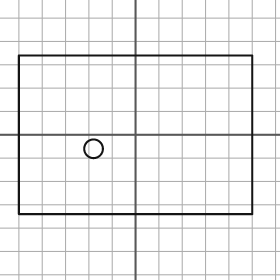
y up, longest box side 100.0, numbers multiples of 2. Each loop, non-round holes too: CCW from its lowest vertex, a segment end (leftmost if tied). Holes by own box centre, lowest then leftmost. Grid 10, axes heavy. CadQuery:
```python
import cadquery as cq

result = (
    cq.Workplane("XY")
    .moveTo(-50.0, -34.0)
    .lineTo(50.0, -34.0)
    .lineTo(50.0, 34.0)
    .lineTo(-50.0, 34.0)
    .close()
    .moveTo(-18.0, -6.0)
    .circle(4.0)
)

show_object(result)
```